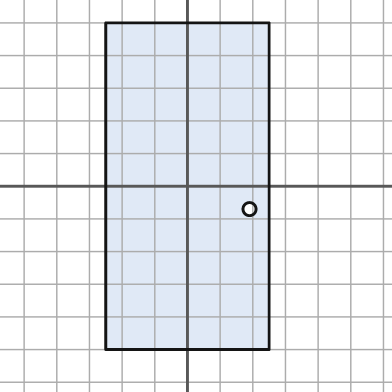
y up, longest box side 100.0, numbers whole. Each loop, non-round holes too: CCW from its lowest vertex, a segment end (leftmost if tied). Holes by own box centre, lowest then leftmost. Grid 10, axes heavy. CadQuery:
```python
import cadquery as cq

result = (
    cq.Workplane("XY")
    .moveTo(-25.0, -50.0)
    .lineTo(25.0, -50.0)
    .lineTo(25.0, 50.0)
    .lineTo(-25.0, 50.0)
    .close()
    .moveTo(19.0, -7.0)
    .circle(2.0)
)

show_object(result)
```